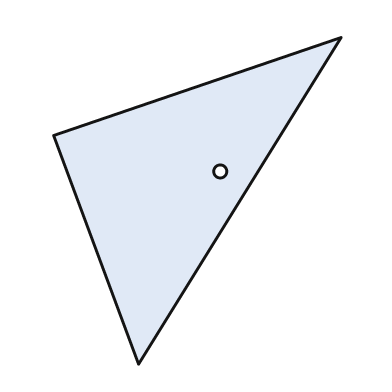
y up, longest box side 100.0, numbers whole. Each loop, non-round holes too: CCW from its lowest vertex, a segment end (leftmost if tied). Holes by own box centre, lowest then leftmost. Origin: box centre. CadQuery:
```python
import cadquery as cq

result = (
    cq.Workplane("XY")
    .moveTo(-18.0, -50.0)
    .lineTo(44.0, 50.0)
    .lineTo(-44.0, 20.0)
    .close()
    .moveTo(7.0, 9.0)
    .circle(2.0)
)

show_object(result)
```